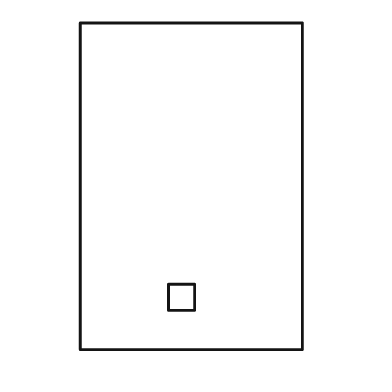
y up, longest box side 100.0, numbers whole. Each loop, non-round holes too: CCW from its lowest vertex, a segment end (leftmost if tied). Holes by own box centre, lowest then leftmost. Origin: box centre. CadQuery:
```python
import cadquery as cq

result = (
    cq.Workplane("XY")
    .moveTo(-34.0, -50.0)
    .lineTo(34.0, -50.0)
    .lineTo(34.0, 50.0)
    .lineTo(-34.0, 50.0)
    .close()
    .moveTo(-7.0, -38.0)
    .lineTo(1.0, -38.0)
    .lineTo(1.0, -30.0)
    .lineTo(-7.0, -30.0)
    .close()
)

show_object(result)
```